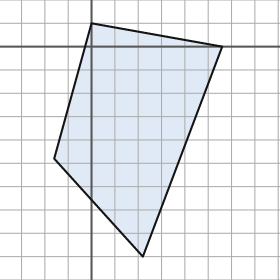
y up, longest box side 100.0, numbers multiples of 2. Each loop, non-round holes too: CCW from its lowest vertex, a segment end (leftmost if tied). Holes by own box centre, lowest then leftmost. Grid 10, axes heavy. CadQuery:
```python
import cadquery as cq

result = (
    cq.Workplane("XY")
    .moveTo(22.0, -90.0)
    .lineTo(56.0, 0.0)
    .lineTo(0.0, 10.0)
    .lineTo(-16.0, -48.0)
    .close()
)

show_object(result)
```